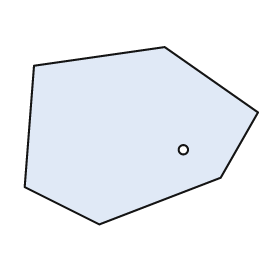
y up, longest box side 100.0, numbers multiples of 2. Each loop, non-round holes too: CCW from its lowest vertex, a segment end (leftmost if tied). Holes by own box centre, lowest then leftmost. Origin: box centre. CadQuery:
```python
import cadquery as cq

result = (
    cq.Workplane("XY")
    .moveTo(-18.0, -38.0)
    .lineTo(34.0, -18.0)
    .lineTo(50.0, 10.0)
    .lineTo(10.0, 38.0)
    .lineTo(-46.0, 30.0)
    .lineTo(-50.0, -22.0)
    .close()
    .moveTo(18.0, -6.0)
    .circle(2.0)
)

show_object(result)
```